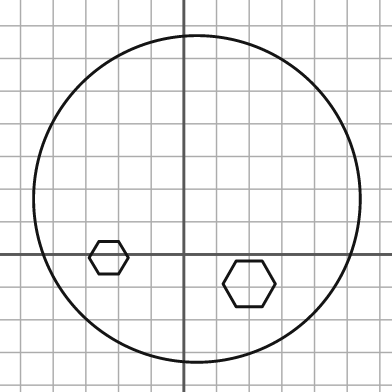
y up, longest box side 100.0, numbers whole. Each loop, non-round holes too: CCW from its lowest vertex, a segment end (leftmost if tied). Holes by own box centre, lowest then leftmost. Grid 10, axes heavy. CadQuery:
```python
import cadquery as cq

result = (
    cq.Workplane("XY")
    .moveTo(4.0, 17.0)
    .circle(50.0)
    .moveTo(16.0, -16.0)
    .lineTo(24.0, -16.0)
    .lineTo(28.0, -9.0)
    .lineTo(24.0, -2.0)
    .lineTo(16.0, -2.0)
    .lineTo(12.0, -9.0)
    .close()
    .moveTo(-26.0, -6.0)
    .lineTo(-20.0, -6.0)
    .lineTo(-17.0, -1.0)
    .lineTo(-20.0, 4.0)
    .lineTo(-26.0, 4.0)
    .lineTo(-29.0, -1.0)
    .close()
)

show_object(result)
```